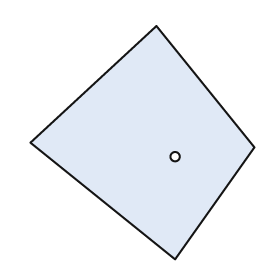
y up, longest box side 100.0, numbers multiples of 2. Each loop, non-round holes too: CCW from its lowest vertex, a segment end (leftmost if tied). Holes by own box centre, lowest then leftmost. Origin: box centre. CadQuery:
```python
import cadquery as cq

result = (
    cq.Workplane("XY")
    .moveTo(14.0, -50.0)
    .lineTo(48.0, -2.0)
    .lineTo(6.0, 50.0)
    .lineTo(-48.0, 0.0)
    .close()
    .moveTo(14.0, -6.0)
    .circle(2.0)
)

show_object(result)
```